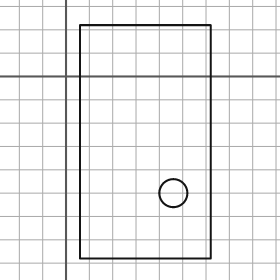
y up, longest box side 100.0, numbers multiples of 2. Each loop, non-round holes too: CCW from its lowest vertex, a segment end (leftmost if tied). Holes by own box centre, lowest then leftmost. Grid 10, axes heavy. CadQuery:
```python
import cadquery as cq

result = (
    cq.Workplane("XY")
    .moveTo(6.0, -78.0)
    .lineTo(62.0, -78.0)
    .lineTo(62.0, 22.0)
    .lineTo(6.0, 22.0)
    .close()
    .moveTo(46.0, -50.0)
    .circle(6.0)
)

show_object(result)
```